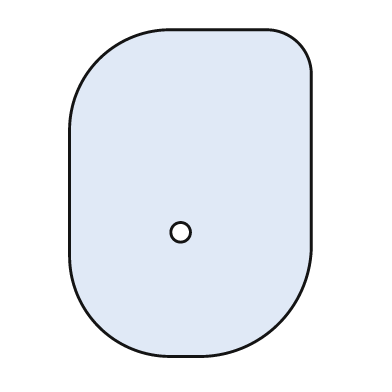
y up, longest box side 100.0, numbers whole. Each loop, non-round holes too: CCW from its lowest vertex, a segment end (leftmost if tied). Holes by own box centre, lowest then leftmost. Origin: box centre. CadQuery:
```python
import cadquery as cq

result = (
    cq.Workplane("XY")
    .moveTo(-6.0, -50.0)
    .lineTo(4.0, -50.0)
    .threePointArc((27.0, -40.0), (37.0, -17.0))
    .lineTo(37.0, 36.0)
    .threePointArc((33.0, 46.0), (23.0, 50.0))
    .lineTo(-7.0, 50.0)
    .threePointArc((-28.0, 41.0), (-37.0, 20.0))
    .lineTo(-37.0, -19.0)
    .threePointArc((-28.0, -41.0), (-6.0, -50.0))
    .close()
    .moveTo(-3.0, -12.0)
    .circle(3.0)
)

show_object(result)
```